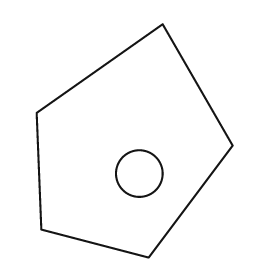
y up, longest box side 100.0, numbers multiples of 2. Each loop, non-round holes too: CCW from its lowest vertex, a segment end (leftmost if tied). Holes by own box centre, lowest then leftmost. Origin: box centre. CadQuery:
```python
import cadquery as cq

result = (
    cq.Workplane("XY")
    .moveTo(6.0, -50.0)
    .lineTo(42.0, -2.0)
    .lineTo(12.0, 50.0)
    .lineTo(-42.0, 12.0)
    .lineTo(-40.0, -38.0)
    .close()
    .moveTo(2.0, -14.0)
    .circle(10.0)
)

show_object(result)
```